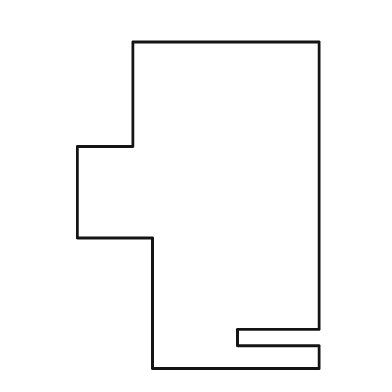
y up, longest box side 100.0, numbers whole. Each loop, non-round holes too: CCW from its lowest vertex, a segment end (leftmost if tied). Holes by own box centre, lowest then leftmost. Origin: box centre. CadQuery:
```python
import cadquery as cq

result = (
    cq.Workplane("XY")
    .moveTo(-14.0, -50.0)
    .lineTo(37.0, -50.0)
    .lineTo(37.0, -43.0)
    .lineTo(12.0, -43.0)
    .lineTo(12.0, -38.0)
    .lineTo(37.0, -38.0)
    .lineTo(37.0, 50.0)
    .lineTo(-20.0, 50.0)
    .lineTo(-20.0, 18.0)
    .lineTo(-37.0, 18.0)
    .lineTo(-37.0, -10.0)
    .lineTo(-14.0, -10.0)
    .close()
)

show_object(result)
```